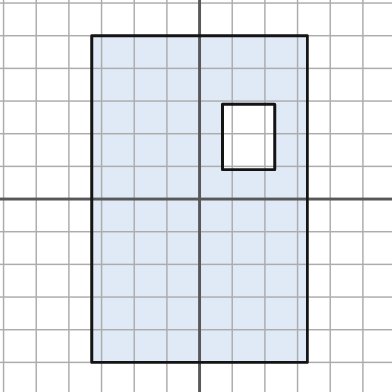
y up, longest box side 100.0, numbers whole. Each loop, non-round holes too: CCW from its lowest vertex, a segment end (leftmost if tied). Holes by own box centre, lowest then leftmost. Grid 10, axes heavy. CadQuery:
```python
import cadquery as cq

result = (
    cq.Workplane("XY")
    .moveTo(-33.0, -50.0)
    .lineTo(33.0, -50.0)
    .lineTo(33.0, 50.0)
    .lineTo(-33.0, 50.0)
    .close()
    .moveTo(7.0, 9.0)
    .lineTo(23.0, 9.0)
    .lineTo(23.0, 29.0)
    .lineTo(7.0, 29.0)
    .close()
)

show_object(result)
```